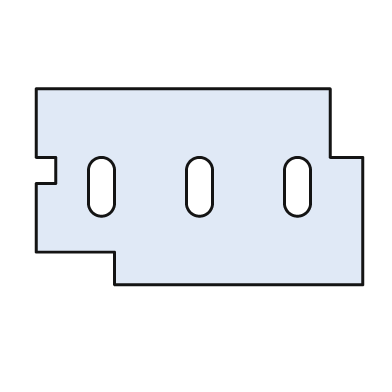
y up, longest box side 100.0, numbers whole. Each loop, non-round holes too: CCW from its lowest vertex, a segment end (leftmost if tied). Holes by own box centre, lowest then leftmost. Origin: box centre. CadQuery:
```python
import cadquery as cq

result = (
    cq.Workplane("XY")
    .moveTo(-26.0, -30.0)
    .lineTo(50.0, -30.0)
    .lineTo(50.0, 9.0)
    .lineTo(40.0, 9.0)
    .lineTo(40.0, 30.0)
    .lineTo(-50.0, 30.0)
    .lineTo(-50.0, 9.0)
    .lineTo(-44.0, 9.0)
    .lineTo(-44.0, 1.0)
    .lineTo(-50.0, 1.0)
    .lineTo(-50.0, -20.0)
    .lineTo(-26.0, -20.0)
    .close()
    .moveTo(-34.0, -5.0)
    .threePointArc((-30.0, -9.0), (-26.0, -5.0))
    .lineTo(-26.0, 5.0)
    .threePointArc((-30.0, 9.0), (-34.0, 5.0))
    .close()
    .moveTo(-4.0, -5.0)
    .threePointArc((0.0, -9.0), (4.0, -5.0))
    .lineTo(4.0, 5.0)
    .threePointArc((0.0, 9.0), (-4.0, 5.0))
    .close()
    .moveTo(26.0, -5.0)
    .threePointArc((30.0, -9.0), (34.0, -5.0))
    .lineTo(34.0, 5.0)
    .threePointArc((30.0, 9.0), (26.0, 5.0))
    .close()
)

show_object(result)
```